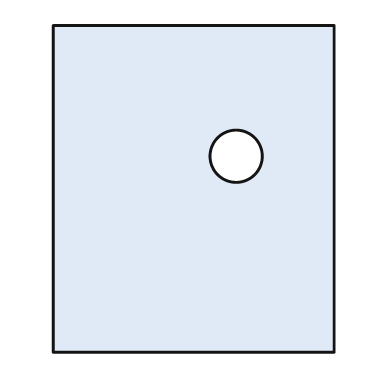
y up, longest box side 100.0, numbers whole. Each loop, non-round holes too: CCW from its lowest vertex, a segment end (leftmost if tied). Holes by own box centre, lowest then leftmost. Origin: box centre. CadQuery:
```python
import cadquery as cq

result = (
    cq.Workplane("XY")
    .moveTo(-43.0, -50.0)
    .lineTo(43.0, -50.0)
    .lineTo(43.0, 50.0)
    .lineTo(-43.0, 50.0)
    .close()
    .moveTo(13.0, 10.0)
    .circle(8.0)
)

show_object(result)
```